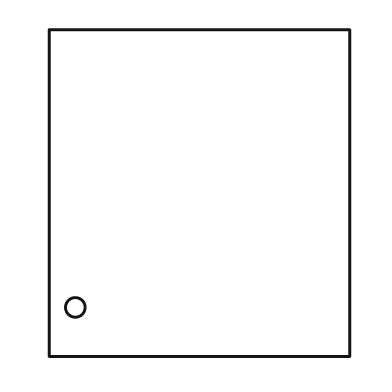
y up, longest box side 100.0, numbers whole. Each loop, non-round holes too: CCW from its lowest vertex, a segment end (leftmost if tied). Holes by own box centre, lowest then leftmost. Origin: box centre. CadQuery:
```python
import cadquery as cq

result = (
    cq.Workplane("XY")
    .moveTo(-46.0, -50.0)
    .lineTo(46.0, -50.0)
    .lineTo(46.0, 50.0)
    .lineTo(-46.0, 50.0)
    .close()
    .moveTo(-38.0, -35.0)
    .circle(3.0)
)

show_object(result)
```